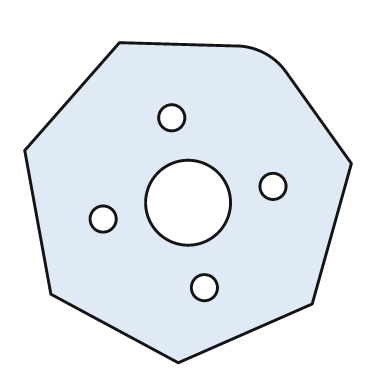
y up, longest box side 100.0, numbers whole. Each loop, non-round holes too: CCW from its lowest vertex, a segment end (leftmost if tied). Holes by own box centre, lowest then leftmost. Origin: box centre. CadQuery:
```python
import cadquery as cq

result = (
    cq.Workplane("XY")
    .moveTo(-3.0, -49.0)
    .lineTo(38.0, -31.0)
    .lineTo(50.0, 12.0)
    .lineTo(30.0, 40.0)
    .threePointArc((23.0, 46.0), (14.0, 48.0))
    .lineTo(-21.0, 49.0)
    .lineTo(-50.0, 16.0)
    .lineTo(-42.0, -28.0)
    .close()
    .moveTo(5.0, -26.0)
    .circle(4.0)
    .moveTo(-26.0, -5.0)
    .circle(4.0)
    .moveTo(0.0, 0.0)
    .circle(13.0)
    .moveTo(26.0, 5.0)
    .circle(4.0)
    .moveTo(-5.0, 26.0)
    .circle(4.0)
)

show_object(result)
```